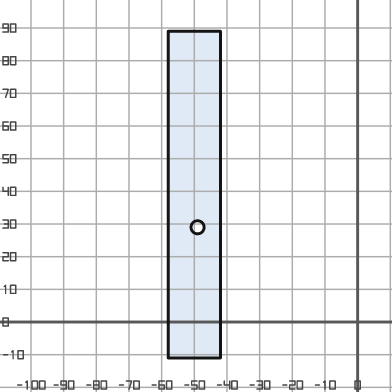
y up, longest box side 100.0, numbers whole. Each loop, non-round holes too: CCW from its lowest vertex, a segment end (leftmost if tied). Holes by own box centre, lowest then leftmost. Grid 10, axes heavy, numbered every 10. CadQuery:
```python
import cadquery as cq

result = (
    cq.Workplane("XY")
    .moveTo(-58.0, -11.0)
    .lineTo(-42.0, -11.0)
    .lineTo(-42.0, 89.0)
    .lineTo(-58.0, 89.0)
    .close()
    .moveTo(-49.0, 29.0)
    .circle(2.0)
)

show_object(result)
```